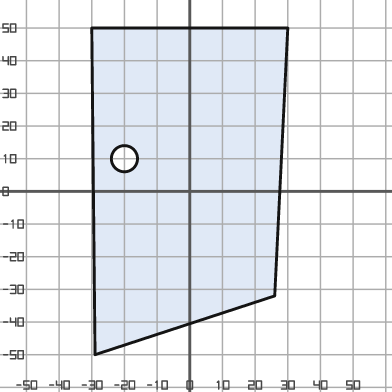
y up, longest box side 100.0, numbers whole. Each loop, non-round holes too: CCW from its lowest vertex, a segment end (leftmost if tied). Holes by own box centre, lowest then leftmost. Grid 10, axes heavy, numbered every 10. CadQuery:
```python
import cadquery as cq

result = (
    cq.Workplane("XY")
    .moveTo(-29.0, -50.0)
    .lineTo(26.0, -32.0)
    .lineTo(30.0, 50.0)
    .lineTo(-30.0, 50.0)
    .close()
    .moveTo(-20.0, 10.0)
    .circle(4.0)
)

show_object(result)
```